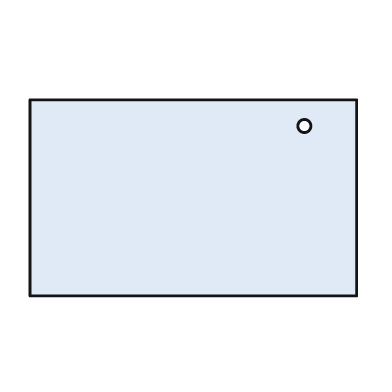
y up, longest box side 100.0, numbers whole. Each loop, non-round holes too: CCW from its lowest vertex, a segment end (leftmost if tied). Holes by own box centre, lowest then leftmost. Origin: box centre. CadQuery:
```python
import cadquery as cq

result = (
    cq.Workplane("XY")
    .moveTo(-50.0, -30.0)
    .lineTo(50.0, -30.0)
    .lineTo(50.0, 30.0)
    .lineTo(-50.0, 30.0)
    .close()
    .moveTo(34.0, 22.0)
    .circle(2.0)
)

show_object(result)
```